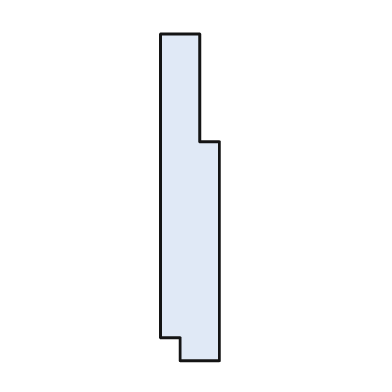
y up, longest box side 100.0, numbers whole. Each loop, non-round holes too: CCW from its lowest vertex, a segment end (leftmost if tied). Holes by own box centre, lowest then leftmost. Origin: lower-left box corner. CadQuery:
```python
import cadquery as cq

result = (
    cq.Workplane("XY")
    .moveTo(6.0, 0.0)
    .lineTo(18.0, 0.0)
    .lineTo(18.0, 67.0)
    .lineTo(12.0, 67.0)
    .lineTo(12.0, 100.0)
    .lineTo(0.0, 100.0)
    .lineTo(0.0, 7.0)
    .lineTo(6.0, 7.0)
    .close()
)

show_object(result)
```